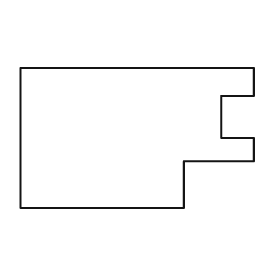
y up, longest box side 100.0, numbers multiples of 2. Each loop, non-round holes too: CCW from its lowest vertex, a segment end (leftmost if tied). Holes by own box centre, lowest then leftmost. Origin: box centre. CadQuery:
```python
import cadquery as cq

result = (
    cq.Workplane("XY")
    .moveTo(-50.0, -30.0)
    .lineTo(20.0, -30.0)
    .lineTo(20.0, -10.0)
    .lineTo(50.0, -10.0)
    .lineTo(50.0, 0.0)
    .lineTo(36.0, 0.0)
    .lineTo(36.0, 18.0)
    .lineTo(50.0, 18.0)
    .lineTo(50.0, 30.0)
    .lineTo(-50.0, 30.0)
    .close()
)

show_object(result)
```